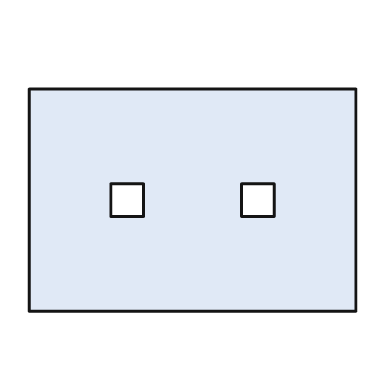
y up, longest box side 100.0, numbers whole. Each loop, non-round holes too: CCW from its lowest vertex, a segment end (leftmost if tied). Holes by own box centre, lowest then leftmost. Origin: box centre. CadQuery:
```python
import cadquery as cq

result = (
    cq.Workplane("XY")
    .moveTo(-50.0, -34.0)
    .lineTo(50.0, -34.0)
    .lineTo(50.0, 34.0)
    .lineTo(-50.0, 34.0)
    .close()
    .moveTo(-25.0, -5.0)
    .lineTo(-15.0, -5.0)
    .lineTo(-15.0, 5.0)
    .lineTo(-25.0, 5.0)
    .close()
    .moveTo(15.0, -5.0)
    .lineTo(25.0, -5.0)
    .lineTo(25.0, 5.0)
    .lineTo(15.0, 5.0)
    .close()
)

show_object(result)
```